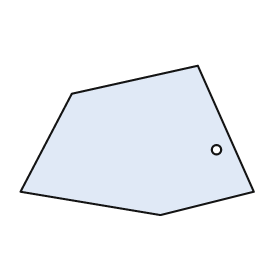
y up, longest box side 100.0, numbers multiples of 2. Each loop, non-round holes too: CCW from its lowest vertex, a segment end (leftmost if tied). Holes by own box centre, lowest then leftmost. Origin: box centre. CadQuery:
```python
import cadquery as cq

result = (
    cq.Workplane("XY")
    .moveTo(10.0, -32.0)
    .lineTo(50.0, -22.0)
    .lineTo(26.0, 32.0)
    .lineTo(-28.0, 20.0)
    .lineTo(-50.0, -22.0)
    .close()
    .moveTo(34.0, -4.0)
    .circle(2.0)
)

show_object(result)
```